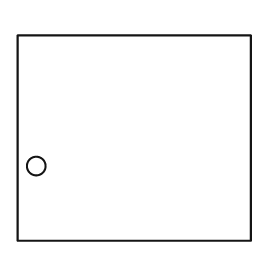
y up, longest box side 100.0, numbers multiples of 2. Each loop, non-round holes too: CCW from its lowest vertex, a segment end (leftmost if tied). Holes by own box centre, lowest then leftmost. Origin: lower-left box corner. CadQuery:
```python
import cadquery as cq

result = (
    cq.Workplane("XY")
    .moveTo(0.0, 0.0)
    .lineTo(100.0, 0.0)
    .lineTo(100.0, 88.0)
    .lineTo(0.0, 88.0)
    .close()
    .moveTo(8.0, 32.0)
    .circle(4.0)
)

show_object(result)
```